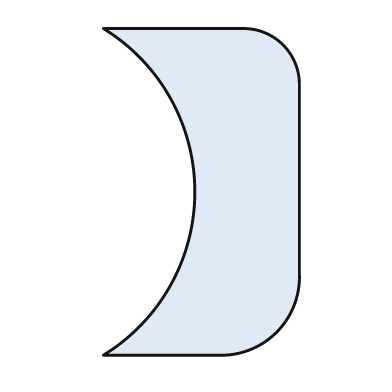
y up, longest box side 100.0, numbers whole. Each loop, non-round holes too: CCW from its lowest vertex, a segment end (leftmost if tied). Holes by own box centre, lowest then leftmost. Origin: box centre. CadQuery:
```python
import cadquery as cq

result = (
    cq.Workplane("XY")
    .moveTo(-30.0, -50.0)
    .lineTo(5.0, -50.0)
    .threePointArc((23.0, -43.0), (30.0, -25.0))
    .lineTo(30.0, 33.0)
    .threePointArc((25.0, 45.0), (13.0, 50.0))
    .lineTo(-30.0, 50.0)
    .threePointArc((-2.0, 0.0), (-30.0, -50.0))
    .close()
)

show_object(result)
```